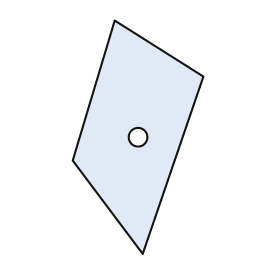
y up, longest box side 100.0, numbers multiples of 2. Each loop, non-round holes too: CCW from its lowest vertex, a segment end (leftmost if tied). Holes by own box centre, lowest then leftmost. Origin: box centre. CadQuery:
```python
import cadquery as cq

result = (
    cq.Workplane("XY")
    .moveTo(2.0, -50.0)
    .lineTo(28.0, 26.0)
    .lineTo(-10.0, 50.0)
    .lineTo(-28.0, -10.0)
    .close()
    .moveTo(0.0, 0.0)
    .circle(4.0)
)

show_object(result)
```